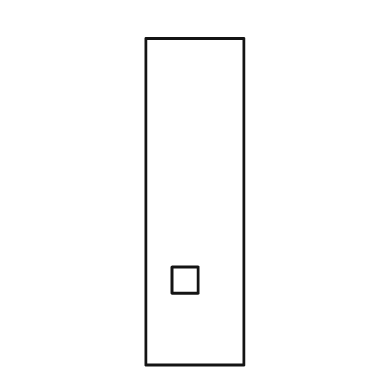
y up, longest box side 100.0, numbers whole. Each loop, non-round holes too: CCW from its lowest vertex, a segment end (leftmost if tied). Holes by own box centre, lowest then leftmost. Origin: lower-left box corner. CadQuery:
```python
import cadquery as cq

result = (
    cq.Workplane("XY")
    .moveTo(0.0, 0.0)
    .lineTo(30.0, 0.0)
    .lineTo(30.0, 100.0)
    .lineTo(0.0, 100.0)
    .close()
    .moveTo(8.0, 22.0)
    .lineTo(16.0, 22.0)
    .lineTo(16.0, 30.0)
    .lineTo(8.0, 30.0)
    .close()
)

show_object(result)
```